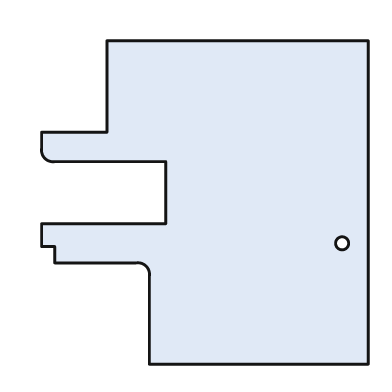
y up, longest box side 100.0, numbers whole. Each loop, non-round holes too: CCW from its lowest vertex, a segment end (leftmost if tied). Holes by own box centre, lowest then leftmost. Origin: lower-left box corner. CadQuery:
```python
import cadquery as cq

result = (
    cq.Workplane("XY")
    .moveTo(33.0, 0.0)
    .lineTo(100.0, 0.0)
    .lineTo(100.0, 99.0)
    .lineTo(20.0, 99.0)
    .lineTo(20.0, 71.0)
    .lineTo(0.0, 71.0)
    .lineTo(0.0, 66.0)
    .threePointArc((1.0, 63.0), (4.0, 62.0))
    .lineTo(38.0, 62.0)
    .lineTo(38.0, 43.0)
    .lineTo(0.0, 43.0)
    .lineTo(0.0, 36.0)
    .lineTo(4.0, 36.0)
    .lineTo(4.0, 31.0)
    .lineTo(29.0, 31.0)
    .threePointArc((32.0, 30.0), (33.0, 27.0))
    .close()
    .moveTo(92.0, 37.0)
    .circle(2.0)
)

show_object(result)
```